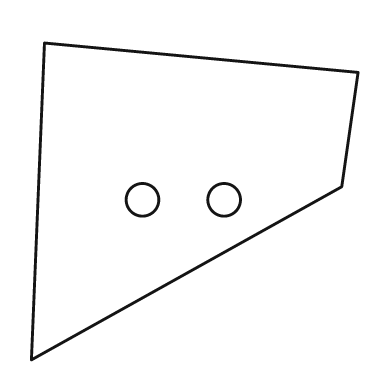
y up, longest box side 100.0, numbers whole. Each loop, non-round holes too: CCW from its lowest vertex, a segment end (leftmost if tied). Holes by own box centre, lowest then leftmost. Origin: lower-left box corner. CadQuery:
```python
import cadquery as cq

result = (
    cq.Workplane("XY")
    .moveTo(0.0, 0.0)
    .lineTo(95.0, 53.0)
    .lineTo(100.0, 88.0)
    .lineTo(4.0, 97.0)
    .close()
    .moveTo(34.0, 49.0)
    .circle(5.0)
    .moveTo(59.0, 49.0)
    .circle(5.0)
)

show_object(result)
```